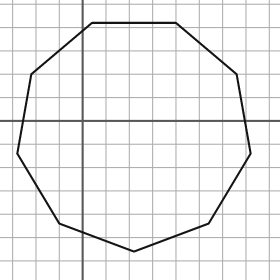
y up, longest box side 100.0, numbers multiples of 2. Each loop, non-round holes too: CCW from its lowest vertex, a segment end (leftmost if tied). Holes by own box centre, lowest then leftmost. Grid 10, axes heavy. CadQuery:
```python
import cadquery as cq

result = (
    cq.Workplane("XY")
    .moveTo(22.0, -56.0)
    .lineTo(54.0, -44.0)
    .lineTo(72.0, -14.0)
    .lineTo(66.0, 20.0)
    .lineTo(40.0, 42.0)
    .lineTo(4.0, 42.0)
    .lineTo(-22.0, 20.0)
    .lineTo(-28.0, -14.0)
    .lineTo(-10.0, -44.0)
    .close()
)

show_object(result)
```